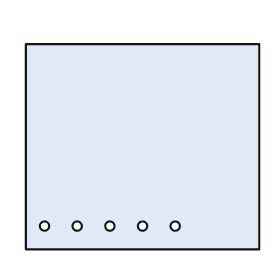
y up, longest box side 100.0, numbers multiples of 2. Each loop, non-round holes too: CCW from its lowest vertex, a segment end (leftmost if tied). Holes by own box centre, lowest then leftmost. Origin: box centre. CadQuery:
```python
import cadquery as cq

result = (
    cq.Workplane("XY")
    .moveTo(-50.0, -44.0)
    .lineTo(50.0, -44.0)
    .lineTo(50.0, 44.0)
    .lineTo(-50.0, 44.0)
    .close()
    .moveTo(-42.0, -34.0)
    .circle(2.0)
    .moveTo(-28.0, -34.0)
    .circle(2.0)
    .moveTo(-14.0, -34.0)
    .circle(2.0)
    .moveTo(0.0, -34.0)
    .circle(2.0)
    .moveTo(14.0, -34.0)
    .circle(2.0)
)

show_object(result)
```